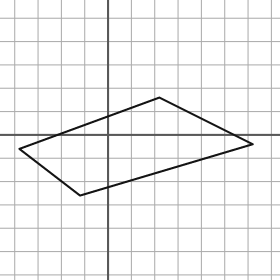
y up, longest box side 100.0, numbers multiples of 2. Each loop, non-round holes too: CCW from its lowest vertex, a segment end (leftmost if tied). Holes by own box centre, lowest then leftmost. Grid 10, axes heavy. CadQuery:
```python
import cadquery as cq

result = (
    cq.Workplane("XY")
    .moveTo(-12.0, -26.0)
    .lineTo(62.0, -4.0)
    .lineTo(22.0, 16.0)
    .lineTo(-38.0, -6.0)
    .close()
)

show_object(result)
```